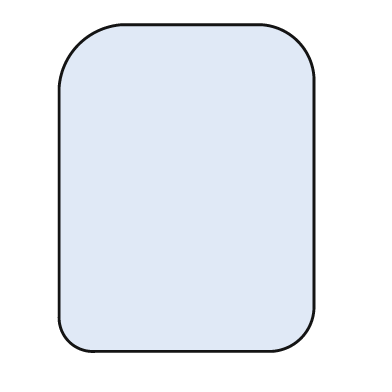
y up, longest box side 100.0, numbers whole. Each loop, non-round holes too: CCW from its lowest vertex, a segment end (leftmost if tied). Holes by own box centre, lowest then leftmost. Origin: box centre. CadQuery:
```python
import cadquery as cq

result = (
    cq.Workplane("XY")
    .moveTo(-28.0, -50.0)
    .lineTo(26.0, -50.0)
    .threePointArc((35.0, -46.0), (39.0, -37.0))
    .lineTo(39.0, 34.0)
    .threePointArc((34.0, 45.0), (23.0, 50.0))
    .lineTo(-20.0, 50.0)
    .threePointArc((-33.0, 44.0), (-39.0, 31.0))
    .lineTo(-39.0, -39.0)
    .threePointArc((-36.0, -47.0), (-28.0, -50.0))
    .close()
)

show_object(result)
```